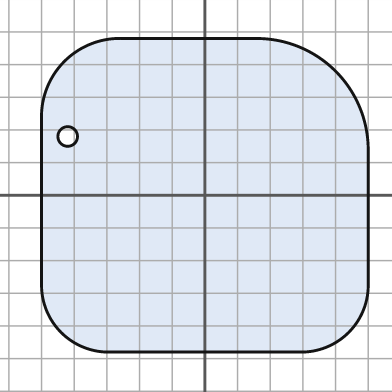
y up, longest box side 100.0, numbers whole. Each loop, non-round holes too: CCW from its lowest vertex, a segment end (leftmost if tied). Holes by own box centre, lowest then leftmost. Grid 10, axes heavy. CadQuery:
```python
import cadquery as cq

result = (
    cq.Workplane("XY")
    .moveTo(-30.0, -48.0)
    .lineTo(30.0, -48.0)
    .threePointArc((44.0, -42.0), (50.0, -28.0))
    .lineTo(50.0, 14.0)
    .threePointArc((40.0, 38.0), (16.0, 48.0))
    .lineTo(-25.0, 48.0)
    .threePointArc((-43.0, 41.0), (-50.0, 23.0))
    .lineTo(-50.0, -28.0)
    .threePointArc((-44.0, -42.0), (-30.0, -48.0))
    .close()
    .moveTo(-42.0, 18.0)
    .circle(3.0)
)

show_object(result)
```